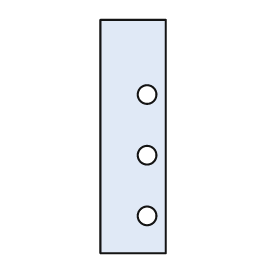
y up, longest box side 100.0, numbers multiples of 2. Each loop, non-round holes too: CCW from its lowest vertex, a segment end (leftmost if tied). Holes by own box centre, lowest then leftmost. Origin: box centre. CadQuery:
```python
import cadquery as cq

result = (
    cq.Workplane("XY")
    .moveTo(-14.0, -50.0)
    .lineTo(14.0, -50.0)
    .lineTo(14.0, 50.0)
    .lineTo(-14.0, 50.0)
    .close()
    .moveTo(6.0, -34.0)
    .circle(4.0)
    .moveTo(6.0, -8.0)
    .circle(4.0)
    .moveTo(6.0, 18.0)
    .circle(4.0)
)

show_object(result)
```